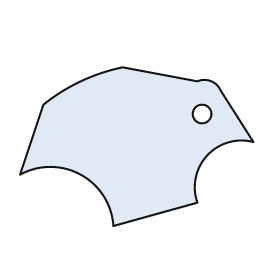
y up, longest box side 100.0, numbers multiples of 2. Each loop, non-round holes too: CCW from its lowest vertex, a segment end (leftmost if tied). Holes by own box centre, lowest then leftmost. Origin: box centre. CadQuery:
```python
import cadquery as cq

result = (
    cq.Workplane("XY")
    .moveTo(-10.0, -34.0)
    .lineTo(26.0, -24.0)
    .threePointArc((30.0, -4.0), (50.0, 2.0))
    .lineTo(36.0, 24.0)
    .threePointArc((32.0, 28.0), (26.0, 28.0))
    .lineTo(-6.0, 34.0)
    .threePointArc((-24.0, 28.0), (-40.0, 18.0))
    .lineTo(-50.0, -12.0)
    .threePointArc((-24.0, -12.0), (-10.0, -34.0))
    .close()
    .moveTo(28.0, 14.0)
    .circle(4.0)
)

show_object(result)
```